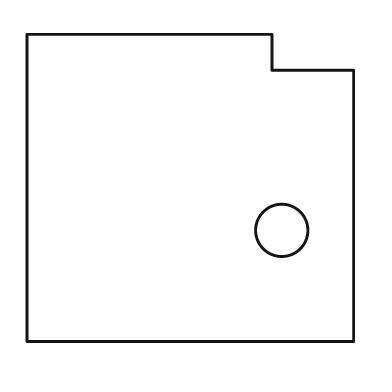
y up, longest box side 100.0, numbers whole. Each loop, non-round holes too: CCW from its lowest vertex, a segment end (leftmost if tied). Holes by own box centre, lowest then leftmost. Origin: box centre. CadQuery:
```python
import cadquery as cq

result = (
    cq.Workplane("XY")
    .moveTo(-50.0, -47.0)
    .lineTo(50.0, -47.0)
    .lineTo(50.0, 36.0)
    .lineTo(25.0, 36.0)
    .lineTo(25.0, 47.0)
    .lineTo(-50.0, 47.0)
    .close()
    .moveTo(28.0, -13.0)
    .circle(8.0)
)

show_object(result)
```